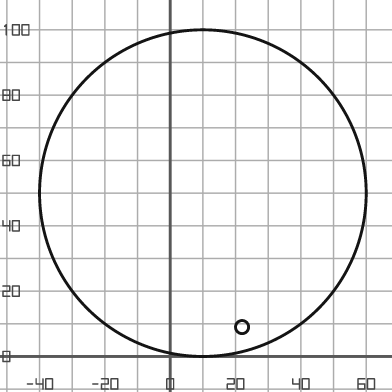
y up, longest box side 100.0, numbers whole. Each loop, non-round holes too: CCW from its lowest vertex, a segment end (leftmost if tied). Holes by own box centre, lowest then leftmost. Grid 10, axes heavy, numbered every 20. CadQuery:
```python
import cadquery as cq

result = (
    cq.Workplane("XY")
    .moveTo(10.0, 50.0)
    .circle(50.0)
    .moveTo(22.0, 9.0)
    .circle(2.0)
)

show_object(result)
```